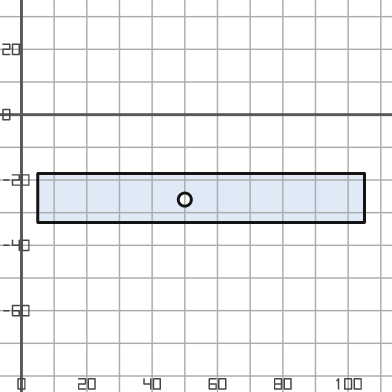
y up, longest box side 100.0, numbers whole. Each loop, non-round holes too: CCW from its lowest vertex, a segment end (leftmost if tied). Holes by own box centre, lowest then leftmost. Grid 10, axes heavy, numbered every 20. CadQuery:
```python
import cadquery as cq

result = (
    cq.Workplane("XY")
    .moveTo(5.0, -33.0)
    .lineTo(105.0, -33.0)
    .lineTo(105.0, -18.0)
    .lineTo(5.0, -18.0)
    .close()
    .moveTo(50.0, -26.0)
    .circle(2.0)
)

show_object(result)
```